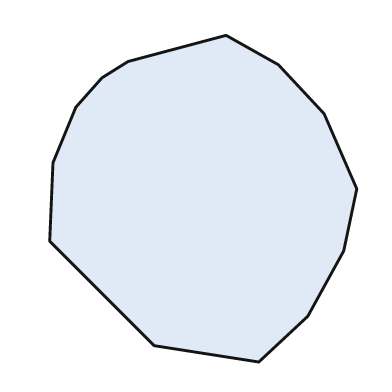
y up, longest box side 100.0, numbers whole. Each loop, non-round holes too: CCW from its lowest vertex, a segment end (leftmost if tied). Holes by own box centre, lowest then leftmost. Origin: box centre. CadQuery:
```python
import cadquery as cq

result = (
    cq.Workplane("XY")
    .moveTo(17.0, -50.0)
    .lineTo(32.0, -36.0)
    .lineTo(43.0, -16.0)
    .lineTo(47.0, 3.0)
    .lineTo(37.0, 26.0)
    .lineTo(23.0, 41.0)
    .lineTo(7.0, 50.0)
    .lineTo(-23.0, 42.0)
    .lineTo(-31.0, 37.0)
    .lineTo(-39.0, 28.0)
    .lineTo(-46.0, 11.0)
    .lineTo(-47.0, -13.0)
    .lineTo(-15.0, -45.0)
    .close()
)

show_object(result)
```